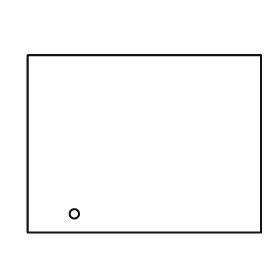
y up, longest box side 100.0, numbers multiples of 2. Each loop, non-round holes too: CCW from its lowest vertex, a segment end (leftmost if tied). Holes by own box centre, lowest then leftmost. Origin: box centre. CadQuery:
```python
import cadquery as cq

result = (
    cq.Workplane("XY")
    .moveTo(-50.0, -38.0)
    .lineTo(50.0, -38.0)
    .lineTo(50.0, 38.0)
    .lineTo(-50.0, 38.0)
    .close()
    .moveTo(-30.0, -30.0)
    .circle(2.0)
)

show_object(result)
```